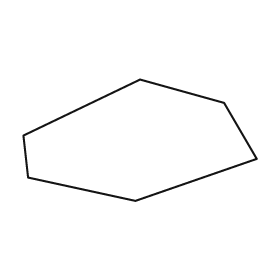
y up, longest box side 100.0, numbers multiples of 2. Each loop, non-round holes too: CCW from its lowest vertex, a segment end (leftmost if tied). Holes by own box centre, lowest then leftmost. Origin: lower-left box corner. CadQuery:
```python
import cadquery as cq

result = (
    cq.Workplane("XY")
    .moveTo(48.0, 0.0)
    .lineTo(100.0, 18.0)
    .lineTo(86.0, 42.0)
    .lineTo(50.0, 52.0)
    .lineTo(0.0, 28.0)
    .lineTo(2.0, 10.0)
    .close()
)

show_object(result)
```